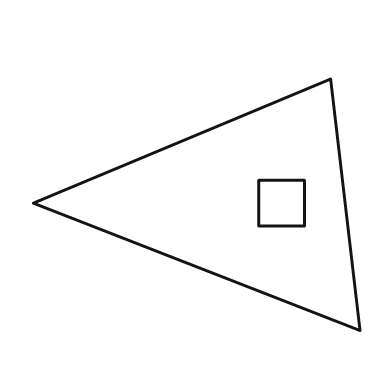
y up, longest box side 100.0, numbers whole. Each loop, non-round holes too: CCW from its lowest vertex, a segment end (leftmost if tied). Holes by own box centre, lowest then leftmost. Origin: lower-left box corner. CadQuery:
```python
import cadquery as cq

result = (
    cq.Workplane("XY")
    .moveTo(100.0, 0.0)
    .lineTo(91.0, 77.0)
    .lineTo(0.0, 39.0)
    .close()
    .moveTo(69.0, 32.0)
    .lineTo(83.0, 32.0)
    .lineTo(83.0, 46.0)
    .lineTo(69.0, 46.0)
    .close()
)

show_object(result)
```